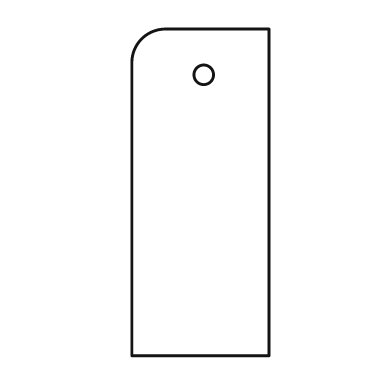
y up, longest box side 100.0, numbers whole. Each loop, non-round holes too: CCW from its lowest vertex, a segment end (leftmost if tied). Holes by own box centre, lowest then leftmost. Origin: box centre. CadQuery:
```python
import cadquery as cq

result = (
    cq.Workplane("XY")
    .moveTo(-21.0, -50.0)
    .lineTo(21.0, -50.0)
    .lineTo(21.0, 50.0)
    .lineTo(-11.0, 50.0)
    .threePointArc((-18.0, 47.0), (-21.0, 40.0))
    .close()
    .moveTo(1.0, 36.0)
    .circle(3.0)
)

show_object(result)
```